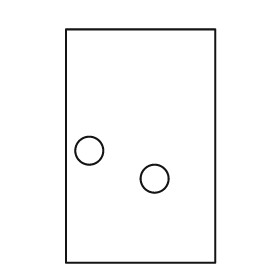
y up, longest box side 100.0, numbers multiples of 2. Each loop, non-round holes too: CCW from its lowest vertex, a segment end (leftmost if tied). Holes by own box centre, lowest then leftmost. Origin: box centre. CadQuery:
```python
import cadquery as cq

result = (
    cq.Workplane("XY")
    .moveTo(-32.0, -50.0)
    .lineTo(32.0, -50.0)
    .lineTo(32.0, 50.0)
    .lineTo(-32.0, 50.0)
    .close()
    .moveTo(6.0, -14.0)
    .circle(6.0)
    .moveTo(-22.0, -2.0)
    .circle(6.0)
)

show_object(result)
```